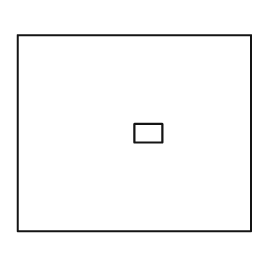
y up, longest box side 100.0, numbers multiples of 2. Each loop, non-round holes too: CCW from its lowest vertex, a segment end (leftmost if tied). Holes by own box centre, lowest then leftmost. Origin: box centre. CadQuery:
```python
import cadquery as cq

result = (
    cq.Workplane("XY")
    .moveTo(-50.0, -42.0)
    .lineTo(50.0, -42.0)
    .lineTo(50.0, 42.0)
    .lineTo(-50.0, 42.0)
    .close()
    .moveTo(0.0, -4.0)
    .lineTo(12.0, -4.0)
    .lineTo(12.0, 4.0)
    .lineTo(0.0, 4.0)
    .close()
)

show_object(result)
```